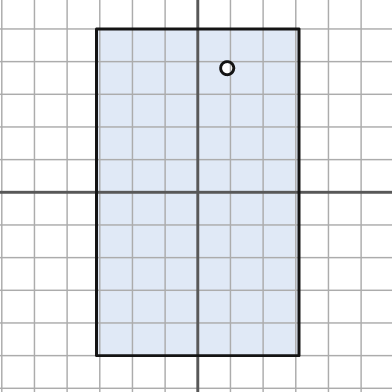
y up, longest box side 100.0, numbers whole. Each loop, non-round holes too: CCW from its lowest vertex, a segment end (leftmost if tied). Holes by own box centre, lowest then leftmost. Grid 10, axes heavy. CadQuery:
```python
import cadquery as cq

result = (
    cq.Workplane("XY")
    .moveTo(-31.0, -50.0)
    .lineTo(31.0, -50.0)
    .lineTo(31.0, 50.0)
    .lineTo(-31.0, 50.0)
    .close()
    .moveTo(9.0, 38.0)
    .circle(2.0)
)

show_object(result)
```